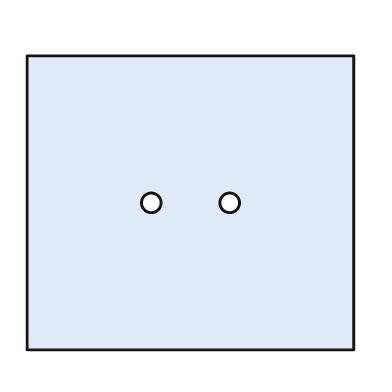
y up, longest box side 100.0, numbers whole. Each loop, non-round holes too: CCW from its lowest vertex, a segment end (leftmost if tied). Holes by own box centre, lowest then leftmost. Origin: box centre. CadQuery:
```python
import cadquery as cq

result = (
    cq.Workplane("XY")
    .moveTo(-50.0, -45.0)
    .lineTo(50.0, -45.0)
    .lineTo(50.0, 45.0)
    .lineTo(-50.0, 45.0)
    .close()
    .moveTo(-12.0, 0.0)
    .circle(3.0)
    .moveTo(12.0, 0.0)
    .circle(3.0)
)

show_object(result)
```